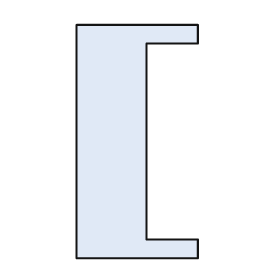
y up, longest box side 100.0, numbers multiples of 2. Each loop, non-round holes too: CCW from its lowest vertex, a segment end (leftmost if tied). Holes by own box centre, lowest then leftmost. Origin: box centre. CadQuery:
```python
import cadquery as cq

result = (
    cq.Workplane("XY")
    .moveTo(-26.0, -50.0)
    .lineTo(26.0, -50.0)
    .lineTo(26.0, -42.0)
    .lineTo(4.0, -42.0)
    .lineTo(4.0, 42.0)
    .lineTo(26.0, 42.0)
    .lineTo(26.0, 50.0)
    .lineTo(-26.0, 50.0)
    .close()
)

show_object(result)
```